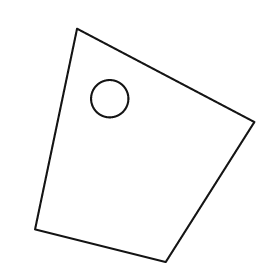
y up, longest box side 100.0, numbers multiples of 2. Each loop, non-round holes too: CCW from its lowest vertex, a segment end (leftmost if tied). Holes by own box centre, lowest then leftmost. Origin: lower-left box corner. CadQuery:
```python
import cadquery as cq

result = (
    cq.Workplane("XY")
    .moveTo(56.0, 0.0)
    .lineTo(94.0, 60.0)
    .lineTo(18.0, 100.0)
    .lineTo(0.0, 14.0)
    .close()
    .moveTo(32.0, 70.0)
    .circle(8.0)
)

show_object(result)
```